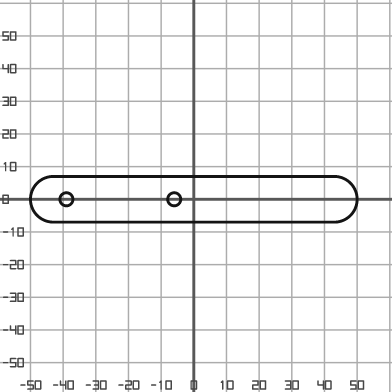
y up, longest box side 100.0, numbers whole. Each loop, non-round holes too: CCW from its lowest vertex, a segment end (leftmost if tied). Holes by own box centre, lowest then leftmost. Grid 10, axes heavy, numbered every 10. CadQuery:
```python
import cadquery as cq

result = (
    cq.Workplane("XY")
    .moveTo(-43.0, -7.0)
    .lineTo(43.0, -7.0)
    .threePointArc((50.0, 0.0), (43.0, 7.0))
    .lineTo(-43.0, 7.0)
    .threePointArc((-50.0, 0.0), (-43.0, -7.0))
    .close()
    .moveTo(-39.0, 0.0)
    .circle(2.0)
    .moveTo(-6.0, 0.0)
    .circle(2.0)
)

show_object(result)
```